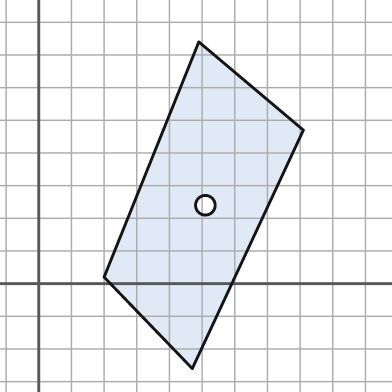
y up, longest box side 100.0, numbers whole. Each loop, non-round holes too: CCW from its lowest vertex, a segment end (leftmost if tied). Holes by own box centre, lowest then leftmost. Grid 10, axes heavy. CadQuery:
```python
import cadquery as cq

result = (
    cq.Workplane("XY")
    .moveTo(47.0, -26.0)
    .lineTo(81.0, 47.0)
    .lineTo(49.0, 74.0)
    .lineTo(20.0, 2.0)
    .close()
    .moveTo(51.0, 24.0)
    .circle(3.0)
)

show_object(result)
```